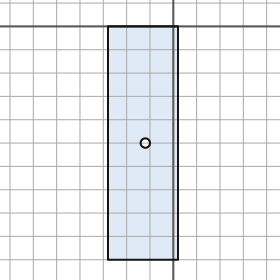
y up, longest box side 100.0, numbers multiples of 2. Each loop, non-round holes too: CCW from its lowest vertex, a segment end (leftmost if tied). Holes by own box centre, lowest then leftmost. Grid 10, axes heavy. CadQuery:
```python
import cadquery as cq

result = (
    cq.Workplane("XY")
    .moveTo(-28.0, -100.0)
    .lineTo(2.0, -100.0)
    .lineTo(2.0, 0.0)
    .lineTo(-28.0, 0.0)
    .close()
    .moveTo(-12.0, -50.0)
    .circle(2.0)
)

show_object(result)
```